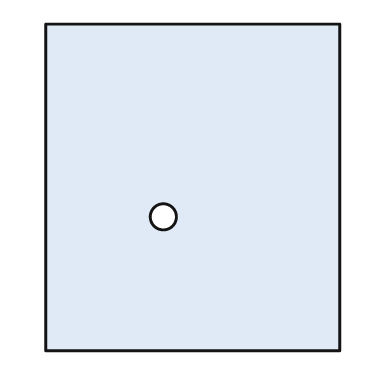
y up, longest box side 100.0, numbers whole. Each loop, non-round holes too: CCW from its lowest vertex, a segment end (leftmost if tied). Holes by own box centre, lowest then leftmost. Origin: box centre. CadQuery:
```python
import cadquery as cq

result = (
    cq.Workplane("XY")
    .moveTo(-45.0, -50.0)
    .lineTo(45.0, -50.0)
    .lineTo(45.0, 50.0)
    .lineTo(-45.0, 50.0)
    .close()
    .moveTo(-9.0, -9.0)
    .circle(4.0)
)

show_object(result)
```